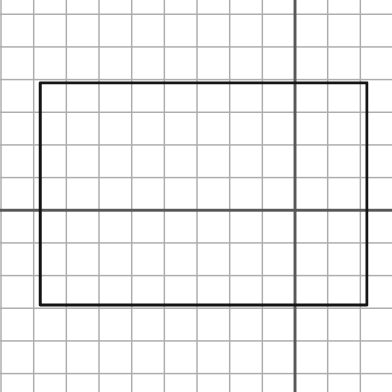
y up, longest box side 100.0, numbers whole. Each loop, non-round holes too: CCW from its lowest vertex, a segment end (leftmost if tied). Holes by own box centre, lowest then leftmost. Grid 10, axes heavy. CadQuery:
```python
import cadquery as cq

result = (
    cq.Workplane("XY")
    .moveTo(-78.0, -29.0)
    .lineTo(22.0, -29.0)
    .lineTo(22.0, 39.0)
    .lineTo(-78.0, 39.0)
    .close()
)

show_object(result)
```